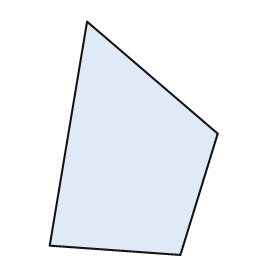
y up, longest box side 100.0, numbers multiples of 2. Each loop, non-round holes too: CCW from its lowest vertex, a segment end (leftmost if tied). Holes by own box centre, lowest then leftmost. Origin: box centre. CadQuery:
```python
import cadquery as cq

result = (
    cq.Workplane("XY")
    .moveTo(20.0, -50.0)
    .lineTo(36.0, 2.0)
    .lineTo(-20.0, 50.0)
    .lineTo(-36.0, -46.0)
    .close()
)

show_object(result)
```